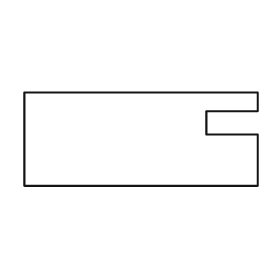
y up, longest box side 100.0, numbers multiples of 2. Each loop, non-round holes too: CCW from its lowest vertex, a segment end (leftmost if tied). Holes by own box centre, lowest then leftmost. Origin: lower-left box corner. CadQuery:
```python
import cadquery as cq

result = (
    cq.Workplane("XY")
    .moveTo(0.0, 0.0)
    .lineTo(100.0, 0.0)
    .lineTo(100.0, 22.0)
    .lineTo(78.0, 22.0)
    .lineTo(78.0, 32.0)
    .lineTo(100.0, 32.0)
    .lineTo(100.0, 40.0)
    .lineTo(0.0, 40.0)
    .close()
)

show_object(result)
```